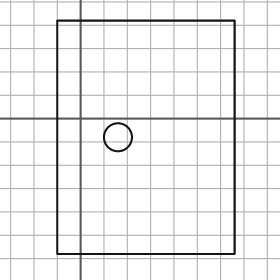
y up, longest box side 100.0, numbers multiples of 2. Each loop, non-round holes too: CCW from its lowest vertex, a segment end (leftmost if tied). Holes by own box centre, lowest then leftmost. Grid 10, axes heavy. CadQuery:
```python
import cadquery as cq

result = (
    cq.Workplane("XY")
    .moveTo(-10.0, -58.0)
    .lineTo(66.0, -58.0)
    .lineTo(66.0, 42.0)
    .lineTo(-10.0, 42.0)
    .close()
    .moveTo(16.0, -8.0)
    .circle(6.0)
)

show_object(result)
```